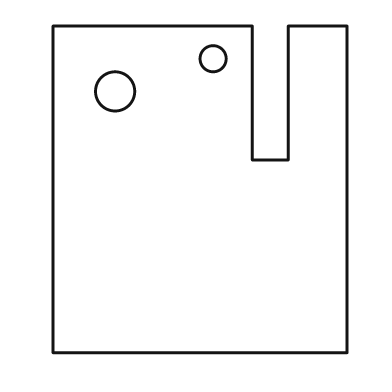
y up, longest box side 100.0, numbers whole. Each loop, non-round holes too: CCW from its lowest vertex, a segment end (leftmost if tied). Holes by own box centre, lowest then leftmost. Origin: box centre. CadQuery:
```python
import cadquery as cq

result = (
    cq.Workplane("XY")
    .moveTo(-45.0, -50.0)
    .lineTo(45.0, -50.0)
    .lineTo(45.0, 50.0)
    .lineTo(27.0, 50.0)
    .lineTo(27.0, 9.0)
    .lineTo(16.0, 9.0)
    .lineTo(16.0, 50.0)
    .lineTo(-45.0, 50.0)
    .close()
    .moveTo(-26.0, 30.0)
    .circle(6.0)
    .moveTo(4.0, 40.0)
    .circle(4.0)
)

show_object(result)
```